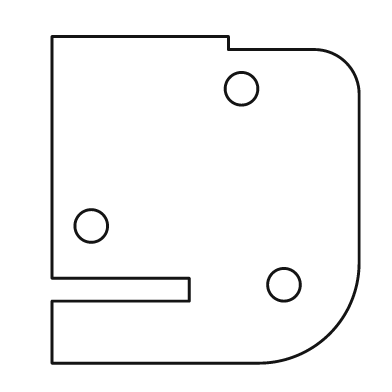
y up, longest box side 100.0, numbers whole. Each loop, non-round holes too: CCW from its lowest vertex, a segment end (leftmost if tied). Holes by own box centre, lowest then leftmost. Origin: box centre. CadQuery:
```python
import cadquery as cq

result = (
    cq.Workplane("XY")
    .moveTo(-47.0, -50.0)
    .lineTo(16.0, -50.0)
    .threePointArc((38.0, -41.0), (47.0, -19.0))
    .lineTo(47.0, 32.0)
    .threePointArc((43.0, 42.0), (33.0, 46.0))
    .lineTo(7.0, 46.0)
    .lineTo(7.0, 50.0)
    .lineTo(-47.0, 50.0)
    .lineTo(-47.0, -24.0)
    .lineTo(-5.0, -24.0)
    .lineTo(-5.0, -31.0)
    .lineTo(-47.0, -31.0)
    .close()
    .moveTo(24.0, -26.0)
    .circle(5.0)
    .moveTo(-35.0, -8.0)
    .circle(5.0)
    .moveTo(11.0, 34.0)
    .circle(5.0)
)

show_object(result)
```